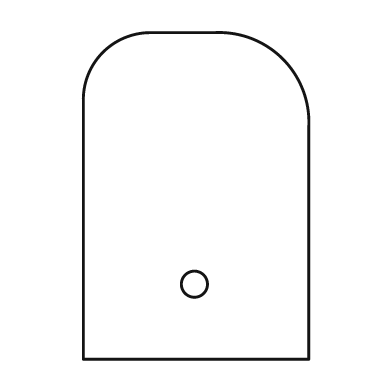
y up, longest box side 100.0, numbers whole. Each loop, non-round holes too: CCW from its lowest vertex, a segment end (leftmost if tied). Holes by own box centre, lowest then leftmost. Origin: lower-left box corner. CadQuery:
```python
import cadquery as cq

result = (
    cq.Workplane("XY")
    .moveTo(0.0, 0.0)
    .lineTo(69.0, 0.0)
    .lineTo(69.0, 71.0)
    .threePointArc((61.0, 92.0), (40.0, 100.0))
    .lineTo(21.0, 100.0)
    .threePointArc((6.0, 94.0), (0.0, 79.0))
    .close()
    .moveTo(34.0, 23.0)
    .circle(4.0)
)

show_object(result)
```